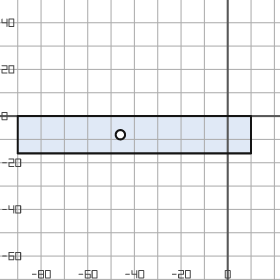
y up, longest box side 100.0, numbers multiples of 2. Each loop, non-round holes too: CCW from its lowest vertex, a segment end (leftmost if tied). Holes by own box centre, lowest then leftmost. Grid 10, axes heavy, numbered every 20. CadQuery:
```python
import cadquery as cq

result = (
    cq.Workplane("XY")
    .moveTo(-90.0, -16.0)
    .lineTo(10.0, -16.0)
    .lineTo(10.0, 0.0)
    .lineTo(-90.0, 0.0)
    .close()
    .moveTo(-46.0, -8.0)
    .circle(2.0)
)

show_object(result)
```